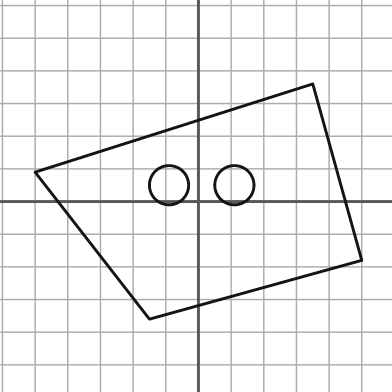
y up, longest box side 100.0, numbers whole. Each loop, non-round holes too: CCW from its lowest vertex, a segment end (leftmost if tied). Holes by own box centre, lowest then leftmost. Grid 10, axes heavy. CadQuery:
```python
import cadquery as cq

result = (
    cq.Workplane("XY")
    .moveTo(-15.0, -36.0)
    .lineTo(50.0, -18.0)
    .lineTo(35.0, 36.0)
    .lineTo(-50.0, 9.0)
    .close()
    .moveTo(-9.0, 5.0)
    .circle(6.0)
    .moveTo(11.0, 5.0)
    .circle(6.0)
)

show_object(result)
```